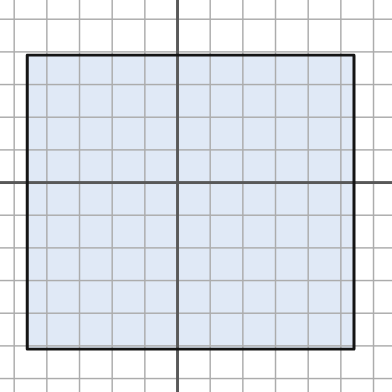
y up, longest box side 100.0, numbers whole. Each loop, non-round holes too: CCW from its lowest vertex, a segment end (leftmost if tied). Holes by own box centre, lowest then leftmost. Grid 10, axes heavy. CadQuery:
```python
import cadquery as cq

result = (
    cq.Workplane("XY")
    .moveTo(-46.0, -51.0)
    .lineTo(54.0, -51.0)
    .lineTo(54.0, 39.0)
    .lineTo(-46.0, 39.0)
    .close()
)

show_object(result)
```